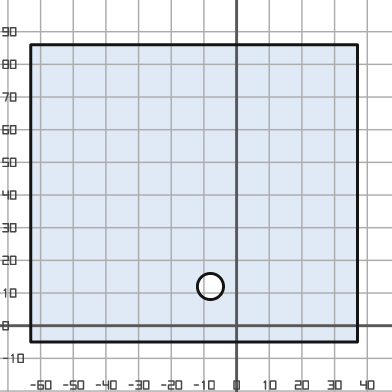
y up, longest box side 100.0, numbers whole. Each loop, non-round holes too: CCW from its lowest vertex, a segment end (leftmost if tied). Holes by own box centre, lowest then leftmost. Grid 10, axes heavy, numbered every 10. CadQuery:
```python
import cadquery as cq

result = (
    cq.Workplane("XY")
    .moveTo(-63.0, -5.0)
    .lineTo(37.0, -5.0)
    .lineTo(37.0, 86.0)
    .lineTo(-63.0, 86.0)
    .close()
    .moveTo(-8.0, 12.0)
    .circle(4.0)
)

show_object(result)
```